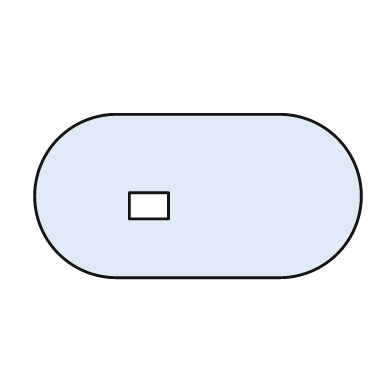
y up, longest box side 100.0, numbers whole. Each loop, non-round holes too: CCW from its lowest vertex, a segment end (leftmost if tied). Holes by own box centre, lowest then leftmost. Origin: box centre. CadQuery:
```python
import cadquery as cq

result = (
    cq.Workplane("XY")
    .moveTo(-25.0, -25.0)
    .lineTo(25.0, -25.0)
    .threePointArc((50.0, 0.0), (25.0, 25.0))
    .lineTo(-25.0, 25.0)
    .threePointArc((-50.0, 0.0), (-25.0, -25.0))
    .close()
    .moveTo(-21.0, -7.0)
    .lineTo(-9.0, -7.0)
    .lineTo(-9.0, 1.0)
    .lineTo(-21.0, 1.0)
    .close()
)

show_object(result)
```